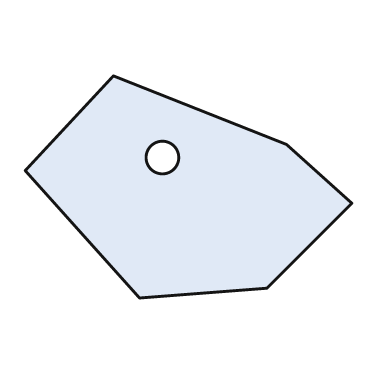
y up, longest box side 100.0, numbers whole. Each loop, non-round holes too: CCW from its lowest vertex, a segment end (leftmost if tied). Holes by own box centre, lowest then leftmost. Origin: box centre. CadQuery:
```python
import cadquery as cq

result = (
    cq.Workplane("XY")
    .moveTo(-15.0, -34.0)
    .lineTo(24.0, -31.0)
    .lineTo(50.0, -5.0)
    .lineTo(30.0, 13.0)
    .lineTo(-23.0, 34.0)
    .lineTo(-50.0, 5.0)
    .close()
    .moveTo(-8.0, 9.0)
    .circle(5.0)
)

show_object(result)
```